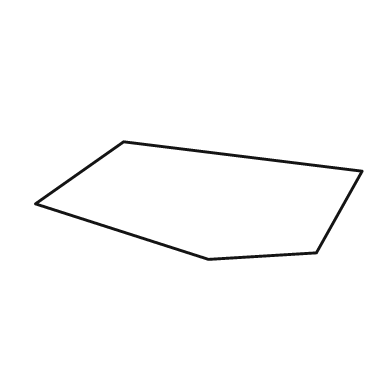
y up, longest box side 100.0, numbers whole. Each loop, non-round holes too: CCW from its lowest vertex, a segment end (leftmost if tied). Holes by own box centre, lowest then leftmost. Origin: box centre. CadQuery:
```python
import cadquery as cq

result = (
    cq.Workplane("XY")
    .moveTo(3.0, -18.0)
    .lineTo(36.0, -16.0)
    .lineTo(50.0, 9.0)
    .lineTo(-23.0, 18.0)
    .lineTo(-50.0, -1.0)
    .close()
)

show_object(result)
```